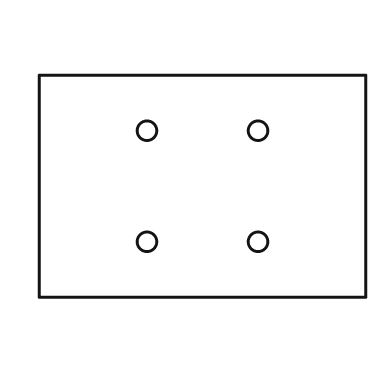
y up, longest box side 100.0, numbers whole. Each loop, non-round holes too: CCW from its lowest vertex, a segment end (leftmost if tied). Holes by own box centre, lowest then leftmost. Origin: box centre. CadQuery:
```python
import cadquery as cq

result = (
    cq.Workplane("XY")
    .moveTo(-50.0, -34.0)
    .lineTo(50.0, -34.0)
    .lineTo(50.0, 34.0)
    .lineTo(-50.0, 34.0)
    .close()
    .moveTo(-17.0, -17.0)
    .circle(3.0)
    .moveTo(17.0, -17.0)
    .circle(3.0)
    .moveTo(-17.0, 17.0)
    .circle(3.0)
    .moveTo(17.0, 17.0)
    .circle(3.0)
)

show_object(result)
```